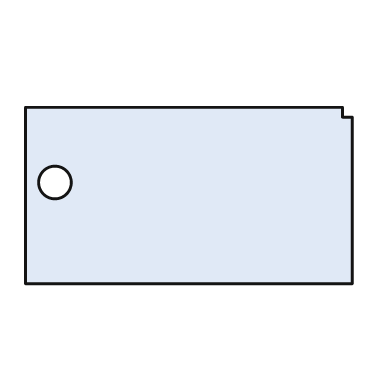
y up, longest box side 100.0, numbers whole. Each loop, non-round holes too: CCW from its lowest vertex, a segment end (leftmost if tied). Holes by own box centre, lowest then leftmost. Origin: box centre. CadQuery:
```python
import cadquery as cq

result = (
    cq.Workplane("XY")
    .moveTo(-50.0, -27.0)
    .lineTo(50.0, -27.0)
    .lineTo(50.0, 24.0)
    .lineTo(47.0, 24.0)
    .lineTo(47.0, 27.0)
    .lineTo(-50.0, 27.0)
    .close()
    .moveTo(-41.0, 4.0)
    .circle(5.0)
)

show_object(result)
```